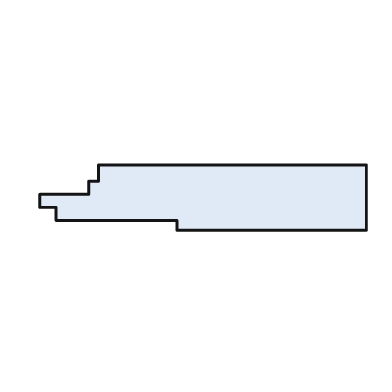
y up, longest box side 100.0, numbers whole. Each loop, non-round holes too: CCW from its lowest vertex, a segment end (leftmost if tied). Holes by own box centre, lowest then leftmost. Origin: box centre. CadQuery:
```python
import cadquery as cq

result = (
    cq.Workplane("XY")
    .moveTo(-8.0, -10.0)
    .lineTo(50.0, -10.0)
    .lineTo(50.0, 10.0)
    .lineTo(-32.0, 10.0)
    .lineTo(-32.0, 5.0)
    .lineTo(-35.0, 5.0)
    .lineTo(-35.0, 1.0)
    .lineTo(-50.0, 1.0)
    .lineTo(-50.0, -3.0)
    .lineTo(-45.0, -3.0)
    .lineTo(-45.0, -7.0)
    .lineTo(-8.0, -7.0)
    .close()
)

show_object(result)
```